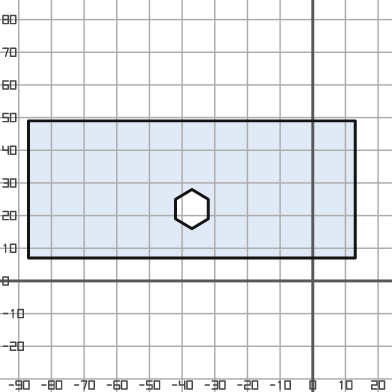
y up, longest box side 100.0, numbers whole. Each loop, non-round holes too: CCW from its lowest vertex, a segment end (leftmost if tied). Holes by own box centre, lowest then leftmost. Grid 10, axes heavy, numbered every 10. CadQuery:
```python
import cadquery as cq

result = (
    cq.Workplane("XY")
    .moveTo(-87.0, 7.0)
    .lineTo(13.0, 7.0)
    .lineTo(13.0, 49.0)
    .lineTo(-87.0, 49.0)
    .close()
    .moveTo(-37.0, 16.0)
    .lineTo(-32.0, 19.0)
    .lineTo(-32.0, 25.0)
    .lineTo(-37.0, 28.0)
    .lineTo(-42.0, 25.0)
    .lineTo(-42.0, 19.0)
    .close()
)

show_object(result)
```